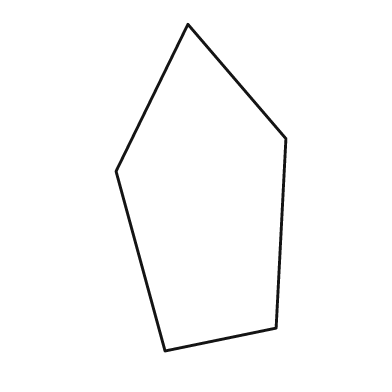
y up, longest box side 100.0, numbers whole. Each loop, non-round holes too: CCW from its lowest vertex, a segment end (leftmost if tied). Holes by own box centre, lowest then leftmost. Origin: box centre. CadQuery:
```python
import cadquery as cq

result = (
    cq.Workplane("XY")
    .moveTo(-11.0, -50.0)
    .lineTo(23.0, -43.0)
    .lineTo(26.0, 15.0)
    .lineTo(-4.0, 50.0)
    .lineTo(-26.0, 5.0)
    .close()
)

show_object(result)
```